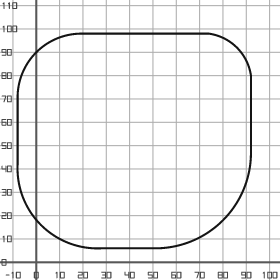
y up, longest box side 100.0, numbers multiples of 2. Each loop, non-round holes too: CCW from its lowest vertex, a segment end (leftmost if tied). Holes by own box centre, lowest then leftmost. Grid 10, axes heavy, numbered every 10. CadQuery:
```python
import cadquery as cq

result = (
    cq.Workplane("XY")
    .moveTo(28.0, 6.0)
    .lineTo(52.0, 6.0)
    .threePointArc((80.0, 18.0), (92.0, 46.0))
    .lineTo(92.0, 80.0)
    .threePointArc((86.0, 92.0), (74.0, 98.0))
    .lineTo(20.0, 98.0)
    .threePointArc((0.0, 90.0), (-8.0, 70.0))
    .lineTo(-8.0, 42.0)
    .threePointArc((2.0, 16.0), (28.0, 6.0))
    .close()
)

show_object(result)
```